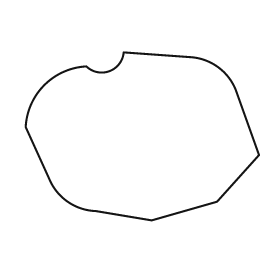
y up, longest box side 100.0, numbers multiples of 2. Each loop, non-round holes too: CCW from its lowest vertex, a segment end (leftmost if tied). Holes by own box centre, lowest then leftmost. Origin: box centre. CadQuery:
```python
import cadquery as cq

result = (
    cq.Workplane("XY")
    .moveTo(4.0, -36.0)
    .lineTo(32.0, -28.0)
    .lineTo(50.0, -8.0)
    .lineTo(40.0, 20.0)
    .threePointArc((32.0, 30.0), (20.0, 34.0))
    .lineTo(-8.0, 36.0)
    .threePointArc((-14.0, 28.0), (-24.0, 30.0))
    .threePointArc((-42.0, 22.0), (-50.0, 4.0))
    .lineTo(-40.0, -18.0)
    .threePointArc((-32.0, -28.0), (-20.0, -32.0))
    .close()
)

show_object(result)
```